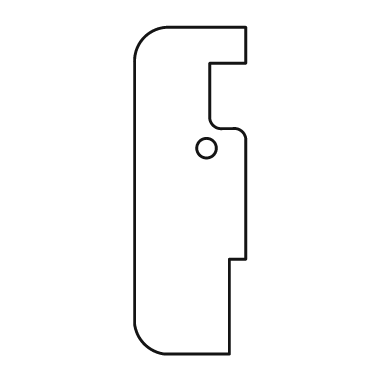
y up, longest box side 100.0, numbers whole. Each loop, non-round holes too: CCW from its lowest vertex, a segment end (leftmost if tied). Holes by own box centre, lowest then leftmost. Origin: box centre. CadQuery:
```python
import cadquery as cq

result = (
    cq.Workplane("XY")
    .moveTo(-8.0, -50.0)
    .lineTo(12.0, -50.0)
    .lineTo(12.0, -21.0)
    .lineTo(17.0, -21.0)
    .lineTo(17.0, 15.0)
    .threePointArc((16.0, 18.0), (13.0, 19.0))
    .lineTo(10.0, 19.0)
    .threePointArc((7.0, 20.0), (6.0, 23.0))
    .lineTo(6.0, 39.0)
    .lineTo(17.0, 39.0)
    .lineTo(17.0, 50.0)
    .lineTo(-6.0, 50.0)
    .threePointArc((-14.0, 47.0), (-17.0, 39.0))
    .lineTo(-17.0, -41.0)
    .threePointArc((-14.0, -47.0), (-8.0, -50.0))
    .close()
    .moveTo(5.0, 13.0)
    .circle(3.0)
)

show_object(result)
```